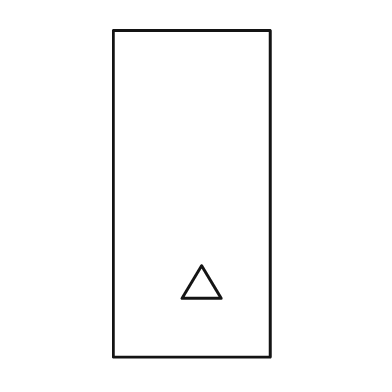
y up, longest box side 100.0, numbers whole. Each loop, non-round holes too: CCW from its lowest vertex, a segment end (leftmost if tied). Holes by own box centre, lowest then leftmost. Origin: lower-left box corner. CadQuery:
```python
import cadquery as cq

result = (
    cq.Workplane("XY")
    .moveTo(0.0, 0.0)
    .lineTo(48.0, 0.0)
    .lineTo(48.0, 100.0)
    .lineTo(0.0, 100.0)
    .close()
    .moveTo(21.0, 18.0)
    .lineTo(33.0, 18.0)
    .lineTo(27.0, 28.0)
    .close()
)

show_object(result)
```